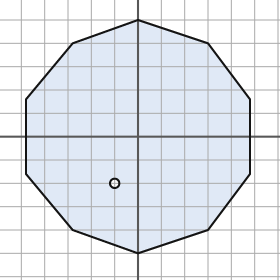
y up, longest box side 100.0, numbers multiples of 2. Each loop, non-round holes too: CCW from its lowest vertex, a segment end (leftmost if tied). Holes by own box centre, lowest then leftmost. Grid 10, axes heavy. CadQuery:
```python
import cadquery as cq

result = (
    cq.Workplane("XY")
    .moveTo(0.0, -50.0)
    .lineTo(30.0, -40.0)
    .lineTo(48.0, -16.0)
    .lineTo(48.0, 16.0)
    .lineTo(30.0, 40.0)
    .lineTo(0.0, 50.0)
    .lineTo(-28.0, 40.0)
    .lineTo(-48.0, 16.0)
    .lineTo(-48.0, -16.0)
    .lineTo(-28.0, -40.0)
    .close()
    .moveTo(-10.0, -20.0)
    .circle(2.0)
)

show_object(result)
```